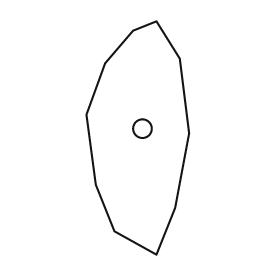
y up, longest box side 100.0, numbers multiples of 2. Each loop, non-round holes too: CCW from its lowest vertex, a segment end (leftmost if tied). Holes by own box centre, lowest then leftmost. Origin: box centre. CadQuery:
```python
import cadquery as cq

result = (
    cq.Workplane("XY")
    .moveTo(8.0, -50.0)
    .lineTo(16.0, -30.0)
    .lineTo(22.0, 2.0)
    .lineTo(18.0, 34.0)
    .lineTo(8.0, 50.0)
    .lineTo(-2.0, 46.0)
    .lineTo(-14.0, 32.0)
    .lineTo(-22.0, 10.0)
    .lineTo(-18.0, -20.0)
    .lineTo(-10.0, -40.0)
    .close()
    .moveTo(2.0, 4.0)
    .circle(4.0)
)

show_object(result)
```